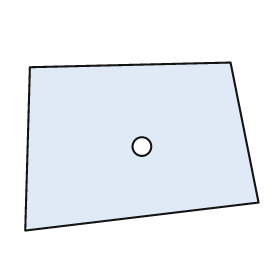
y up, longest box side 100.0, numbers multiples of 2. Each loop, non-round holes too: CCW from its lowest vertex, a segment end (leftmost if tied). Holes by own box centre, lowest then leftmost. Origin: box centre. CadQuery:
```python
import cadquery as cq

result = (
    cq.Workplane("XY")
    .moveTo(-50.0, -36.0)
    .lineTo(50.0, -24.0)
    .lineTo(38.0, 36.0)
    .lineTo(-48.0, 34.0)
    .close()
    .moveTo(0.0, 0.0)
    .circle(4.0)
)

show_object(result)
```